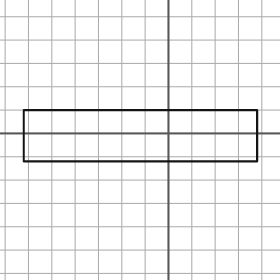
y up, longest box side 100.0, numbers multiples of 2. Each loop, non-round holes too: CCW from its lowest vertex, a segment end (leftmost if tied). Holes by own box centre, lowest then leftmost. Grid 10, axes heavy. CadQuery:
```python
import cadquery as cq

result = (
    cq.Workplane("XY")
    .moveTo(-62.0, -12.0)
    .lineTo(38.0, -12.0)
    .lineTo(38.0, 10.0)
    .lineTo(-62.0, 10.0)
    .close()
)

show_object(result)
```